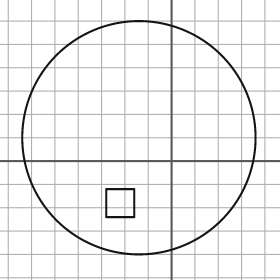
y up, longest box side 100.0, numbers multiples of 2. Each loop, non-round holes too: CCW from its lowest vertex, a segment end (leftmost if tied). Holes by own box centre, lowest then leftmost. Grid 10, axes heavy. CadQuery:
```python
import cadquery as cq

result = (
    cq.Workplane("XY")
    .moveTo(-14.0, 10.0)
    .circle(50.0)
    .moveTo(-28.0, -24.0)
    .lineTo(-16.0, -24.0)
    .lineTo(-16.0, -12.0)
    .lineTo(-28.0, -12.0)
    .close()
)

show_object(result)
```